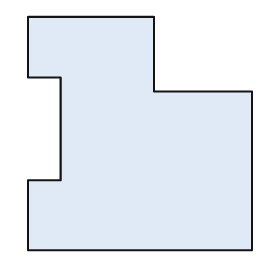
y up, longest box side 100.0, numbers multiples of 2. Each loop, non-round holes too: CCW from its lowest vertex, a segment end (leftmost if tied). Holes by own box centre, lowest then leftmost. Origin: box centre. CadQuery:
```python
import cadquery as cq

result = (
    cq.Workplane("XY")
    .moveTo(-48.0, -50.0)
    .lineTo(48.0, -50.0)
    .lineTo(48.0, 18.0)
    .lineTo(6.0, 18.0)
    .lineTo(6.0, 50.0)
    .lineTo(-48.0, 50.0)
    .lineTo(-48.0, 24.0)
    .lineTo(-34.0, 24.0)
    .lineTo(-34.0, -20.0)
    .lineTo(-48.0, -20.0)
    .close()
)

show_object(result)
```